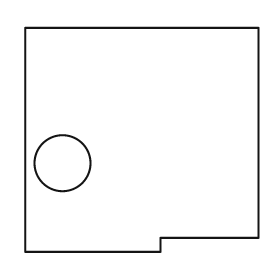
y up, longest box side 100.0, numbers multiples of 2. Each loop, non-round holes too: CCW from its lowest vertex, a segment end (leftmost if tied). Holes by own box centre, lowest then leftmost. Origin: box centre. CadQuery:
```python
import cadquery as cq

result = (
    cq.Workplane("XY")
    .moveTo(-50.0, -48.0)
    .lineTo(8.0, -48.0)
    .lineTo(8.0, -42.0)
    .lineTo(50.0, -42.0)
    .lineTo(50.0, 48.0)
    .lineTo(-50.0, 48.0)
    .close()
    .moveTo(-34.0, -10.0)
    .circle(12.0)
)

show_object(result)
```